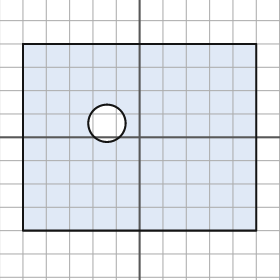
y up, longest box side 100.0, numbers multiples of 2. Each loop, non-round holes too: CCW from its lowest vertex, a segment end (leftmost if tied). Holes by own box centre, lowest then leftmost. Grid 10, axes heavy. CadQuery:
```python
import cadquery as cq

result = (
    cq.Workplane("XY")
    .moveTo(-50.0, -40.0)
    .lineTo(50.0, -40.0)
    .lineTo(50.0, 40.0)
    .lineTo(-50.0, 40.0)
    .close()
    .moveTo(-14.0, 6.0)
    .circle(8.0)
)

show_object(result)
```